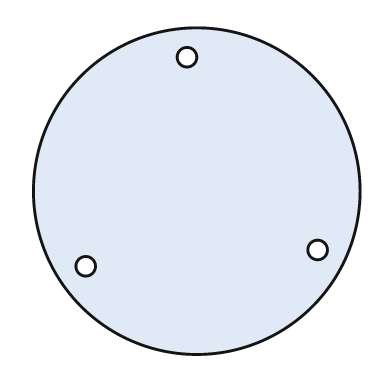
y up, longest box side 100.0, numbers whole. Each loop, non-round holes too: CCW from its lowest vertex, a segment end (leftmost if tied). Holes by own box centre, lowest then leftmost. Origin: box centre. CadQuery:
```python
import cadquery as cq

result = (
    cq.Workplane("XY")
    .moveTo(0.0, 0.0)
    .circle(50.0)
    .moveTo(-34.0, -23.0)
    .circle(3.0)
    .moveTo(37.0, -18.0)
    .circle(3.0)
    .moveTo(-3.0, 41.0)
    .circle(3.0)
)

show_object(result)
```